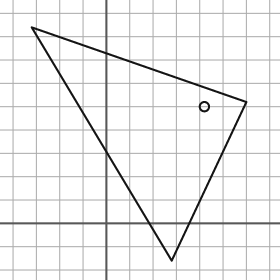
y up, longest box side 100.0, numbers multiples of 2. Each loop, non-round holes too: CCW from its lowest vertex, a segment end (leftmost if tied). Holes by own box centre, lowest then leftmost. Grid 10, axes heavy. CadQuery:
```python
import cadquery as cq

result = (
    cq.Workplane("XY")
    .moveTo(28.0, -16.0)
    .lineTo(60.0, 52.0)
    .lineTo(-32.0, 84.0)
    .close()
    .moveTo(42.0, 50.0)
    .circle(2.0)
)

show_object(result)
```